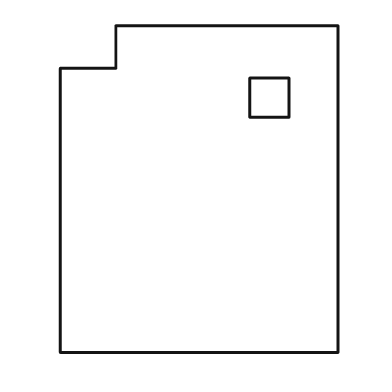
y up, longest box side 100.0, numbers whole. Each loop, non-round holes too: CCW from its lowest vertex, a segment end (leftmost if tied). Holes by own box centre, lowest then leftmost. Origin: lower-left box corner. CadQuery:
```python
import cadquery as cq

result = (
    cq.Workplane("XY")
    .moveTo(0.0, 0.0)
    .lineTo(85.0, 0.0)
    .lineTo(85.0, 100.0)
    .lineTo(17.0, 100.0)
    .lineTo(17.0, 87.0)
    .lineTo(0.0, 87.0)
    .close()
    .moveTo(58.0, 72.0)
    .lineTo(70.0, 72.0)
    .lineTo(70.0, 84.0)
    .lineTo(58.0, 84.0)
    .close()
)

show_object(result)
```